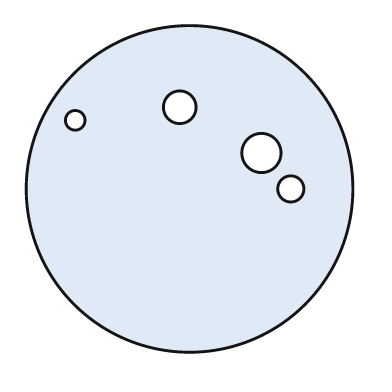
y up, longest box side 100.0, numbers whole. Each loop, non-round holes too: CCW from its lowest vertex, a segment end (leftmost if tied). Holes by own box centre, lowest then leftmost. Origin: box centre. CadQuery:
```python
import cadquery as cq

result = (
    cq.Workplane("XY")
    .moveTo(0.0, 0.0)
    .circle(50.0)
    .moveTo(31.0, 0.0)
    .circle(4.0)
    .moveTo(22.0, 11.0)
    .circle(6.0)
    .moveTo(-35.0, 21.0)
    .circle(3.0)
    .moveTo(-3.0, 25.0)
    .circle(5.0)
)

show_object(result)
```